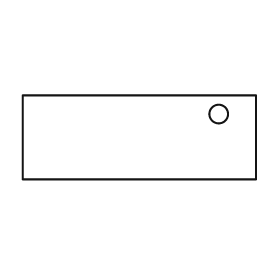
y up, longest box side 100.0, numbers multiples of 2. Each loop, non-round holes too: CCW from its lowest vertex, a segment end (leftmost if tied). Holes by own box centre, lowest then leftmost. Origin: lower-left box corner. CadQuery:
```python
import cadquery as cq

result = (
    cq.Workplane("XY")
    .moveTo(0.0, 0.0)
    .lineTo(100.0, 0.0)
    .lineTo(100.0, 36.0)
    .lineTo(0.0, 36.0)
    .close()
    .moveTo(84.0, 28.0)
    .circle(4.0)
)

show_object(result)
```